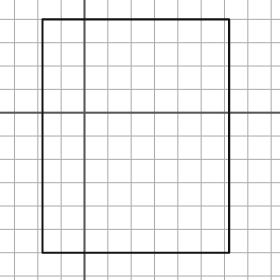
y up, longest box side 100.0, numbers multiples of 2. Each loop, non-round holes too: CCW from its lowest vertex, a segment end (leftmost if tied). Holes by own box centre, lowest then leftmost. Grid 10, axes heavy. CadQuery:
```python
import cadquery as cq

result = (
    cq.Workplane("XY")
    .moveTo(-18.0, -60.0)
    .lineTo(62.0, -60.0)
    .lineTo(62.0, 40.0)
    .lineTo(-18.0, 40.0)
    .close()
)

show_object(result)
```